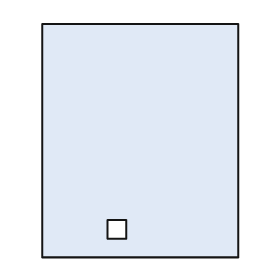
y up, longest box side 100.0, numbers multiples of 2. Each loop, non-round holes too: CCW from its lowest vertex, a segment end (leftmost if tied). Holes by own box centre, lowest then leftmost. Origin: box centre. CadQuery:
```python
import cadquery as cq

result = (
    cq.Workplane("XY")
    .moveTo(-42.0, -50.0)
    .lineTo(42.0, -50.0)
    .lineTo(42.0, 50.0)
    .lineTo(-42.0, 50.0)
    .close()
    .moveTo(-14.0, -42.0)
    .lineTo(-6.0, -42.0)
    .lineTo(-6.0, -34.0)
    .lineTo(-14.0, -34.0)
    .close()
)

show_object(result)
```